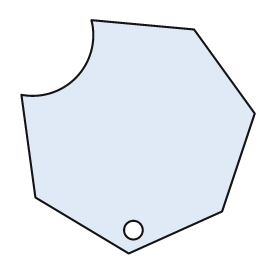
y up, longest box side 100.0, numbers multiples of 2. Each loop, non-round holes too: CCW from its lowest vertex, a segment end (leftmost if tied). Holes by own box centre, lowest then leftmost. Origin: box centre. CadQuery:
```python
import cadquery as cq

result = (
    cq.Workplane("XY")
    .moveTo(-4.0, -50.0)
    .lineTo(36.0, -32.0)
    .lineTo(50.0, 10.0)
    .lineTo(24.0, 46.0)
    .lineTo(-20.0, 50.0)
    .threePointArc((-26.0, 26.0), (-50.0, 18.0))
    .lineTo(-44.0, -26.0)
    .close()
    .moveTo(-2.0, -40.0)
    .circle(4.0)
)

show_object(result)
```